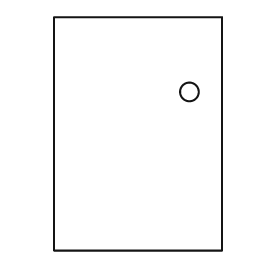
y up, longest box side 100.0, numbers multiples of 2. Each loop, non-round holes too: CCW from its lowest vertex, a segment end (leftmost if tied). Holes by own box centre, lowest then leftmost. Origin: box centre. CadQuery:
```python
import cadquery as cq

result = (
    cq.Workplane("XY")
    .moveTo(-36.0, -50.0)
    .lineTo(36.0, -50.0)
    .lineTo(36.0, 50.0)
    .lineTo(-36.0, 50.0)
    .close()
    .moveTo(22.0, 18.0)
    .circle(4.0)
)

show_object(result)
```